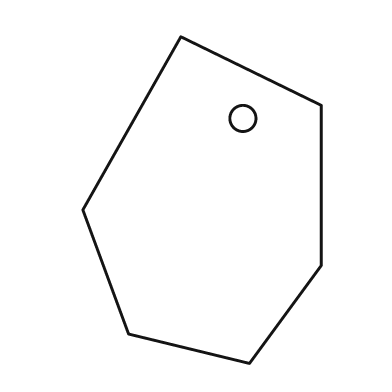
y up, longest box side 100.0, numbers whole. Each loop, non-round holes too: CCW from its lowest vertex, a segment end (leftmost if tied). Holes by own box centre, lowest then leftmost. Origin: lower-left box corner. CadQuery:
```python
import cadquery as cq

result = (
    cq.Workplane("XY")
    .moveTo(51.0, 0.0)
    .lineTo(73.0, 30.0)
    .lineTo(73.0, 79.0)
    .lineTo(30.0, 100.0)
    .lineTo(0.0, 47.0)
    .lineTo(14.0, 9.0)
    .close()
    .moveTo(49.0, 75.0)
    .circle(4.0)
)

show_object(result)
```